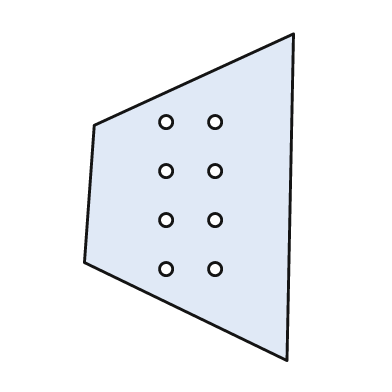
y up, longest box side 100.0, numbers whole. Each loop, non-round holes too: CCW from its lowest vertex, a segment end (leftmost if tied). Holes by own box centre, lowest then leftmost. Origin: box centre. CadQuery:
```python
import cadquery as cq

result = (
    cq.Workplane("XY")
    .moveTo(30.0, -50.0)
    .lineTo(32.0, 50.0)
    .lineTo(-29.0, 22.0)
    .lineTo(-32.0, -20.0)
    .close()
    .moveTo(-7.0, -22.0)
    .circle(2.0)
    .moveTo(8.0, -22.0)
    .circle(2.0)
    .moveTo(-7.0, -7.0)
    .circle(2.0)
    .moveTo(8.0, -7.0)
    .circle(2.0)
    .moveTo(-7.0, 8.0)
    .circle(2.0)
    .moveTo(8.0, 8.0)
    .circle(2.0)
    .moveTo(-7.0, 23.0)
    .circle(2.0)
    .moveTo(8.0, 23.0)
    .circle(2.0)
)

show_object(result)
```